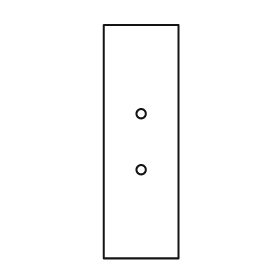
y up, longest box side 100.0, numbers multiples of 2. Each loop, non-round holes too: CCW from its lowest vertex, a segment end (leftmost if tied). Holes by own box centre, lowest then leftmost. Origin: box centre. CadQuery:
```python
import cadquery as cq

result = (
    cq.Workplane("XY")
    .moveTo(-16.0, -50.0)
    .lineTo(16.0, -50.0)
    .lineTo(16.0, 50.0)
    .lineTo(-16.0, 50.0)
    .close()
    .moveTo(0.0, -12.0)
    .circle(2.0)
    .moveTo(0.0, 12.0)
    .circle(2.0)
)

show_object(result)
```